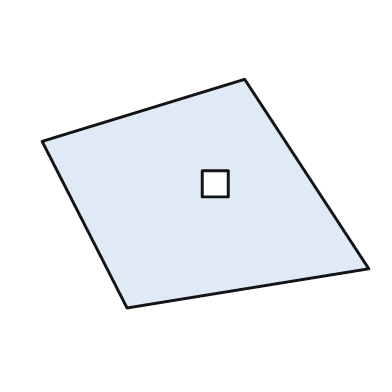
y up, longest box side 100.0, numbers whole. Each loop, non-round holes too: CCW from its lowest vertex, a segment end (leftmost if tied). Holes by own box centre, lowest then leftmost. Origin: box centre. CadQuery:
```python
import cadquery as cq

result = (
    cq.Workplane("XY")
    .moveTo(-24.0, -35.0)
    .lineTo(50.0, -23.0)
    .lineTo(12.0, 35.0)
    .lineTo(-50.0, 16.0)
    .close()
    .moveTo(-1.0, -1.0)
    .lineTo(7.0, -1.0)
    .lineTo(7.0, 7.0)
    .lineTo(-1.0, 7.0)
    .close()
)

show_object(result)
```